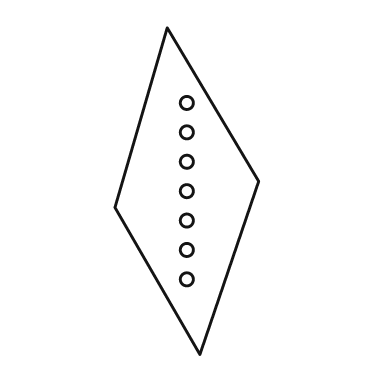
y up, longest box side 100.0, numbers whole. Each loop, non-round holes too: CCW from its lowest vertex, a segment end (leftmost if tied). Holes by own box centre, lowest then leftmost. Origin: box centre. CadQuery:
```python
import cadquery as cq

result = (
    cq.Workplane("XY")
    .moveTo(4.0, -50.0)
    .lineTo(22.0, 3.0)
    .lineTo(-6.0, 50.0)
    .lineTo(-22.0, -5.0)
    .close()
    .moveTo(0.0, -27.0)
    .circle(2.0)
    .moveTo(0.0, -18.0)
    .circle(2.0)
    .moveTo(0.0, -9.0)
    .circle(2.0)
    .moveTo(0.0, 0.0)
    .circle(2.0)
    .moveTo(0.0, 9.0)
    .circle(2.0)
    .moveTo(0.0, 18.0)
    .circle(2.0)
    .moveTo(0.0, 27.0)
    .circle(2.0)
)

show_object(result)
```